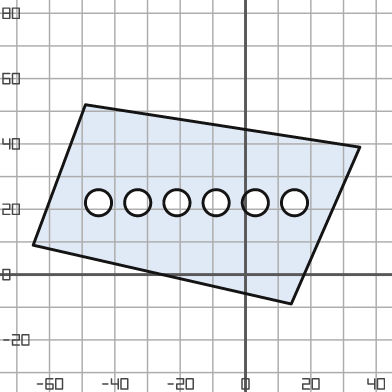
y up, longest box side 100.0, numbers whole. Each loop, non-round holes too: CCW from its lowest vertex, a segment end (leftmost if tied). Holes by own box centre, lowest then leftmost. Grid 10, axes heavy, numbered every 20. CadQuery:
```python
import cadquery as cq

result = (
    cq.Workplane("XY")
    .moveTo(14.0, -9.0)
    .lineTo(35.0, 39.0)
    .lineTo(-49.0, 52.0)
    .lineTo(-65.0, 9.0)
    .close()
    .moveTo(-45.0, 22.0)
    .circle(4.0)
    .moveTo(-33.0, 22.0)
    .circle(4.0)
    .moveTo(-21.0, 22.0)
    .circle(4.0)
    .moveTo(-9.0, 22.0)
    .circle(4.0)
    .moveTo(3.0, 22.0)
    .circle(4.0)
    .moveTo(15.0, 22.0)
    .circle(4.0)
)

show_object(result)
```